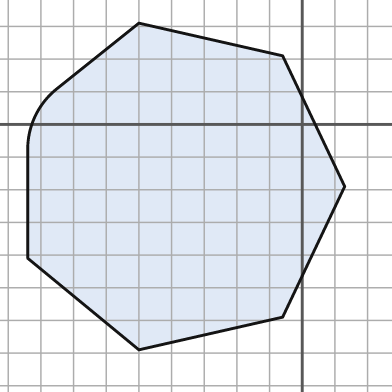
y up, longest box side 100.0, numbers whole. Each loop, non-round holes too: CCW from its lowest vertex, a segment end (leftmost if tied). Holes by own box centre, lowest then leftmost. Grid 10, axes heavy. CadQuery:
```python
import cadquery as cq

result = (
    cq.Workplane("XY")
    .moveTo(-50.0, -69.0)
    .lineTo(-6.0, -59.0)
    .lineTo(13.0, -19.0)
    .lineTo(-6.0, 21.0)
    .lineTo(-50.0, 31.0)
    .lineTo(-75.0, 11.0)
    .threePointArc((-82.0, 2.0), (-84.0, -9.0))
    .lineTo(-84.0, -41.0)
    .close()
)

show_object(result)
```